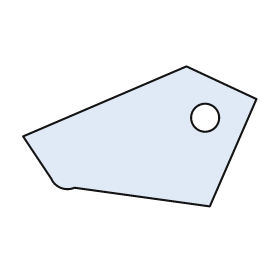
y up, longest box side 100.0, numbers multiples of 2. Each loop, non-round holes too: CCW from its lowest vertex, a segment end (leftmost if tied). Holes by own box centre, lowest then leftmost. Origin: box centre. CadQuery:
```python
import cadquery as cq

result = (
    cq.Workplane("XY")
    .moveTo(30.0, -30.0)
    .lineTo(50.0, 16.0)
    .lineTo(20.0, 30.0)
    .lineTo(-50.0, 0.0)
    .lineTo(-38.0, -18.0)
    .threePointArc((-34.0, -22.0), (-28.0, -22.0))
    .close()
    .moveTo(28.0, 8.0)
    .circle(6.0)
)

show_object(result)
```